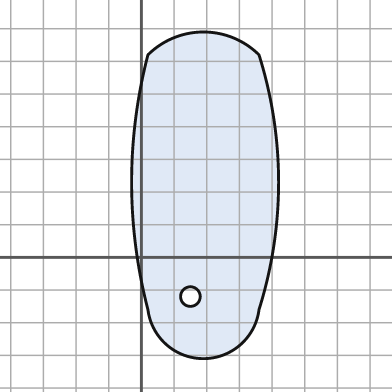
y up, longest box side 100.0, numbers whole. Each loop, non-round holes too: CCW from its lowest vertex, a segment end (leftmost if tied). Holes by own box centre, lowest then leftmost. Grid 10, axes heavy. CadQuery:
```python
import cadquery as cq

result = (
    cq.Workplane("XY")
    .moveTo(2.0, -16.0)
    .threePointArc((19.0, -31.0), (36.0, -16.0))
    .threePointArc((42.0, 23.0), (36.0, 62.0))
    .threePointArc((19.0, 69.0), (2.0, 62.0))
    .threePointArc((-3.0, 23.0), (2.0, -16.0))
    .close()
    .moveTo(15.0, -12.0)
    .circle(3.0)
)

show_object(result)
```